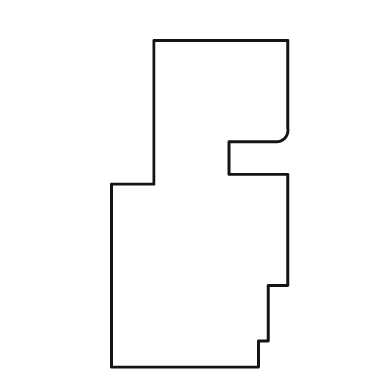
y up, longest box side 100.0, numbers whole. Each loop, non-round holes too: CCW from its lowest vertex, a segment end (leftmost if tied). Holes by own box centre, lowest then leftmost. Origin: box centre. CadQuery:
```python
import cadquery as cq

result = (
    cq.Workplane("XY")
    .moveTo(-27.0, -50.0)
    .lineTo(18.0, -50.0)
    .lineTo(18.0, -42.0)
    .lineTo(21.0, -42.0)
    .lineTo(21.0, -25.0)
    .lineTo(27.0, -25.0)
    .lineTo(27.0, 9.0)
    .lineTo(9.0, 9.0)
    .lineTo(9.0, 19.0)
    .lineTo(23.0, 19.0)
    .threePointArc((26.0, 20.0), (27.0, 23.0))
    .lineTo(27.0, 50.0)
    .lineTo(-14.0, 50.0)
    .lineTo(-14.0, 6.0)
    .lineTo(-27.0, 6.0)
    .close()
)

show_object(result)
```